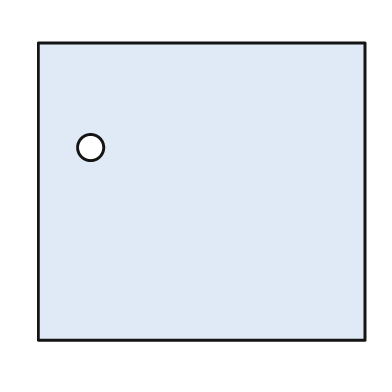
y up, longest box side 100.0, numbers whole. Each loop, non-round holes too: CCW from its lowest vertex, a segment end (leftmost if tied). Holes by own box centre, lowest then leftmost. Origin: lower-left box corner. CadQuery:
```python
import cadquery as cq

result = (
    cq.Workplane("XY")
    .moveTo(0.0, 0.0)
    .lineTo(100.0, 0.0)
    .lineTo(100.0, 91.0)
    .lineTo(0.0, 91.0)
    .close()
    .moveTo(16.0, 59.0)
    .circle(4.0)
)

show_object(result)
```